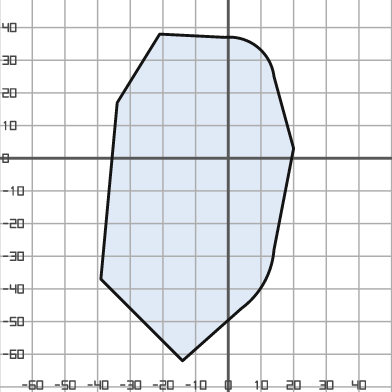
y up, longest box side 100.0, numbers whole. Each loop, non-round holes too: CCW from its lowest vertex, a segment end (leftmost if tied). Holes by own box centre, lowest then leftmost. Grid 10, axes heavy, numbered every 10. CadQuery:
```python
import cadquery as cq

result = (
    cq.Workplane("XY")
    .moveTo(-14.0, -62.0)
    .lineTo(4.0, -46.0)
    .threePointArc((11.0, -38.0), (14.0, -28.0))
    .lineTo(20.0, 3.0)
    .lineTo(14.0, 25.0)
    .threePointArc((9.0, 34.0), (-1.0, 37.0))
    .lineTo(-21.0, 38.0)
    .lineTo(-34.0, 17.0)
    .lineTo(-39.0, -37.0)
    .close()
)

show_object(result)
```